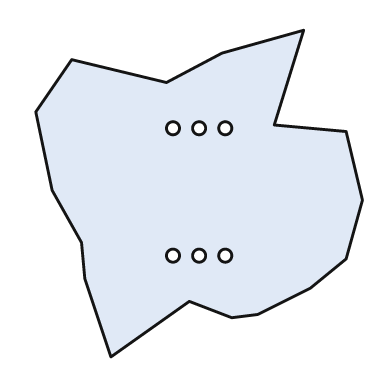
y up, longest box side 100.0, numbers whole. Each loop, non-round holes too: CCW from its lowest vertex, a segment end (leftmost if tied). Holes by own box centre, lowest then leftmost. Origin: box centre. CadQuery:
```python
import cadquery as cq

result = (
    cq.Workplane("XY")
    .moveTo(-27.0, -50.0)
    .lineTo(-3.0, -33.0)
    .lineTo(10.0, -38.0)
    .lineTo(18.0, -37.0)
    .lineTo(34.0, -29.0)
    .lineTo(45.0, -20.0)
    .lineTo(50.0, -2.0)
    .lineTo(45.0, 19.0)
    .lineTo(23.0, 21.0)
    .lineTo(32.0, 50.0)
    .lineTo(7.0, 43.0)
    .lineTo(-10.0, 34.0)
    .lineTo(-39.0, 41.0)
    .lineTo(-50.0, 25.0)
    .lineTo(-45.0, 1.0)
    .lineTo(-36.0, -15.0)
    .lineTo(-35.0, -26.0)
    .close()
    .moveTo(-8.0, -19.0)
    .circle(2.0)
    .moveTo(0.0, -19.0)
    .circle(2.0)
    .moveTo(8.0, -19.0)
    .circle(2.0)
    .moveTo(-8.0, 20.0)
    .circle(2.0)
    .moveTo(0.0, 20.0)
    .circle(2.0)
    .moveTo(8.0, 20.0)
    .circle(2.0)
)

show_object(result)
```